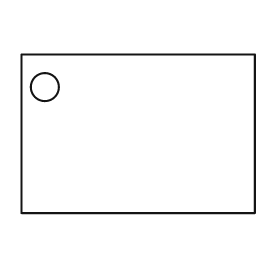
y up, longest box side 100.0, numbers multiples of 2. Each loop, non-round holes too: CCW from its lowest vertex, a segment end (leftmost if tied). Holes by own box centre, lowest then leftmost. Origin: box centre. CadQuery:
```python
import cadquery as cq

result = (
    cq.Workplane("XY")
    .moveTo(-50.0, -34.0)
    .lineTo(50.0, -34.0)
    .lineTo(50.0, 34.0)
    .lineTo(-50.0, 34.0)
    .close()
    .moveTo(-40.0, 20.0)
    .circle(6.0)
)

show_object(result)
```